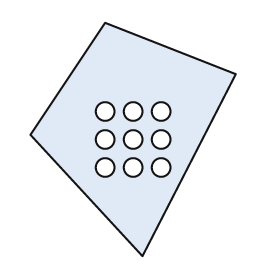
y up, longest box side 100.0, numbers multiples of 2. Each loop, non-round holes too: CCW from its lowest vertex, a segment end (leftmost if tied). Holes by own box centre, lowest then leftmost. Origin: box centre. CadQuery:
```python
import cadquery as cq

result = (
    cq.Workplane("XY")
    .moveTo(4.0, -50.0)
    .lineTo(44.0, 28.0)
    .lineTo(-12.0, 50.0)
    .lineTo(-44.0, 2.0)
    .close()
    .moveTo(-12.0, -12.0)
    .circle(4.0)
    .moveTo(0.0, -12.0)
    .circle(4.0)
    .moveTo(12.0, -12.0)
    .circle(4.0)
    .moveTo(-12.0, 0.0)
    .circle(4.0)
    .moveTo(0.0, 0.0)
    .circle(4.0)
    .moveTo(12.0, 0.0)
    .circle(4.0)
    .moveTo(-12.0, 12.0)
    .circle(4.0)
    .moveTo(0.0, 12.0)
    .circle(4.0)
    .moveTo(12.0, 12.0)
    .circle(4.0)
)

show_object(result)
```